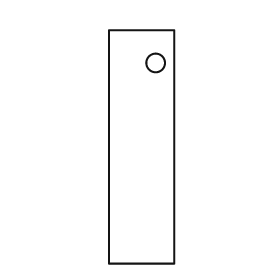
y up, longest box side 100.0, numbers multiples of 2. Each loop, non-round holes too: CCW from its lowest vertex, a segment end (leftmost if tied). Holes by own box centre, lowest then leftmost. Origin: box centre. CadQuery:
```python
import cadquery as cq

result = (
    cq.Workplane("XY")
    .moveTo(-14.0, -50.0)
    .lineTo(14.0, -50.0)
    .lineTo(14.0, 50.0)
    .lineTo(-14.0, 50.0)
    .close()
    .moveTo(6.0, 36.0)
    .circle(4.0)
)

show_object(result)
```